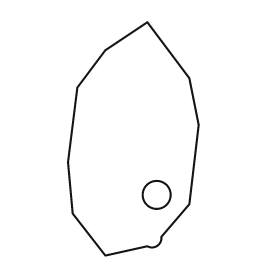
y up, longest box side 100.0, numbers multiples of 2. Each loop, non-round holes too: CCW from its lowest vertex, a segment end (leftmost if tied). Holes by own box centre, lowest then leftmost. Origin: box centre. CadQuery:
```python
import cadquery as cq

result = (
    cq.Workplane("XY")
    .moveTo(-12.0, -50.0)
    .lineTo(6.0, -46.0)
    .threePointArc((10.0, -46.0), (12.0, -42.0))
    .lineTo(24.0, -28.0)
    .lineTo(28.0, 6.0)
    .lineTo(24.0, 26.0)
    .lineTo(6.0, 50.0)
    .lineTo(-12.0, 38.0)
    .lineTo(-24.0, 22.0)
    .lineTo(-28.0, -10.0)
    .lineTo(-26.0, -32.0)
    .close()
    .moveTo(10.0, -24.0)
    .circle(6.0)
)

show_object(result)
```